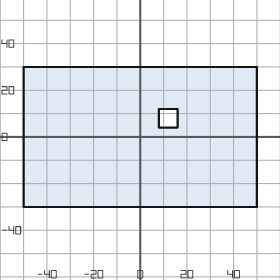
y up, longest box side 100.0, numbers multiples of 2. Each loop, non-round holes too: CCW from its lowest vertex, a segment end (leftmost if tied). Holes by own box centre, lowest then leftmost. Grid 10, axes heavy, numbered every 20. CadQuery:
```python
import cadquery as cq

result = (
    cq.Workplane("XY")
    .moveTo(-50.0, -30.0)
    .lineTo(50.0, -30.0)
    .lineTo(50.0, 30.0)
    .lineTo(-50.0, 30.0)
    .close()
    .moveTo(8.0, 4.0)
    .lineTo(16.0, 4.0)
    .lineTo(16.0, 12.0)
    .lineTo(8.0, 12.0)
    .close()
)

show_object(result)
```